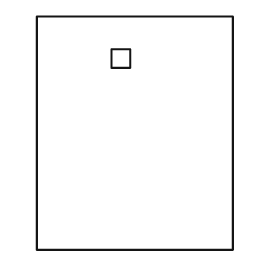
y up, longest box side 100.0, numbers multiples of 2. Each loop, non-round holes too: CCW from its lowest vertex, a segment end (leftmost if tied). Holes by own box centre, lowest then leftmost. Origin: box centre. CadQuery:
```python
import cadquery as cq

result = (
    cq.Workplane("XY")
    .moveTo(-42.0, -50.0)
    .lineTo(42.0, -50.0)
    .lineTo(42.0, 50.0)
    .lineTo(-42.0, 50.0)
    .close()
    .moveTo(-10.0, 28.0)
    .lineTo(-2.0, 28.0)
    .lineTo(-2.0, 36.0)
    .lineTo(-10.0, 36.0)
    .close()
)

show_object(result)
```